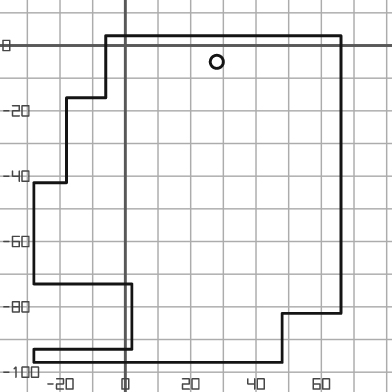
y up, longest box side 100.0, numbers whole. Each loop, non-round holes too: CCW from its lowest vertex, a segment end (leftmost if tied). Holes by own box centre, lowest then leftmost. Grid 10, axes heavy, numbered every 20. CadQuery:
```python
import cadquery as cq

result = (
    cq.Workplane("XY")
    .moveTo(-28.0, -97.0)
    .lineTo(48.0, -97.0)
    .lineTo(48.0, -82.0)
    .lineTo(66.0, -82.0)
    .lineTo(66.0, 3.0)
    .lineTo(-6.0, 3.0)
    .lineTo(-6.0, -16.0)
    .lineTo(-18.0, -16.0)
    .lineTo(-18.0, -42.0)
    .lineTo(-28.0, -42.0)
    .lineTo(-28.0, -73.0)
    .lineTo(2.0, -73.0)
    .lineTo(2.0, -93.0)
    .lineTo(-28.0, -93.0)
    .close()
    .moveTo(28.0, -5.0)
    .circle(2.0)
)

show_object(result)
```